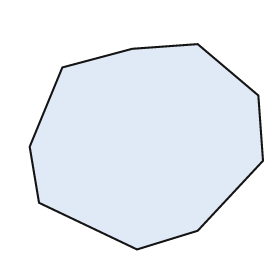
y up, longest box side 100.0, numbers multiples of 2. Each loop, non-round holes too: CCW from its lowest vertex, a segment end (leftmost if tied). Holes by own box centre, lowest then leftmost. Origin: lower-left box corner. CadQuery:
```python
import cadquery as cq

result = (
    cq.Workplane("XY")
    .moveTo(46.0, 0.0)
    .lineTo(72.0, 8.0)
    .lineTo(100.0, 38.0)
    .lineTo(98.0, 66.0)
    .lineTo(72.0, 88.0)
    .lineTo(44.0, 86.0)
    .lineTo(14.0, 78.0)
    .lineTo(0.0, 44.0)
    .lineTo(4.0, 20.0)
    .close()
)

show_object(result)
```